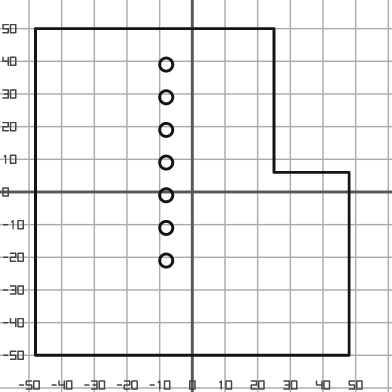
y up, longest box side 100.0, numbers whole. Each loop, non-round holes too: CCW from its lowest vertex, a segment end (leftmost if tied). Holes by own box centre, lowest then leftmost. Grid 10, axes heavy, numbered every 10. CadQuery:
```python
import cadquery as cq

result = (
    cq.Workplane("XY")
    .moveTo(-48.0, -50.0)
    .lineTo(48.0, -50.0)
    .lineTo(48.0, 6.0)
    .lineTo(25.0, 6.0)
    .lineTo(25.0, 50.0)
    .lineTo(-48.0, 50.0)
    .close()
    .moveTo(-8.0, -21.0)
    .circle(2.0)
    .moveTo(-8.0, -11.0)
    .circle(2.0)
    .moveTo(-8.0, -1.0)
    .circle(2.0)
    .moveTo(-8.0, 9.0)
    .circle(2.0)
    .moveTo(-8.0, 19.0)
    .circle(2.0)
    .moveTo(-8.0, 29.0)
    .circle(2.0)
    .moveTo(-8.0, 39.0)
    .circle(2.0)
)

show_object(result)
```